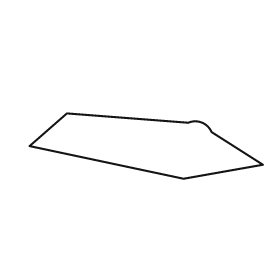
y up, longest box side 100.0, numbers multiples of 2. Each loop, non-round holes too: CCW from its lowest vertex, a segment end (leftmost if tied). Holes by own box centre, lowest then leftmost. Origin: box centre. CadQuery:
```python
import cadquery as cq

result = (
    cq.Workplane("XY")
    .moveTo(16.0, -14.0)
    .lineTo(50.0, -8.0)
    .lineTo(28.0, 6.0)
    .threePointArc((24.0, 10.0), (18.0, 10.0))
    .lineTo(-34.0, 14.0)
    .lineTo(-50.0, 0.0)
    .close()
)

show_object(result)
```